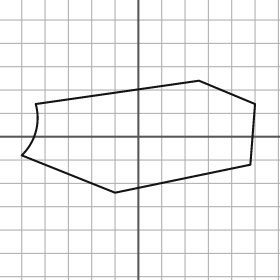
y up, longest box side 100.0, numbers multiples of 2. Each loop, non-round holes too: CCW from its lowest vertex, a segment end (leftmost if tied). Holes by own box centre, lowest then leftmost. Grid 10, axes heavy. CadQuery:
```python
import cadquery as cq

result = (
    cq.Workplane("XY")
    .moveTo(-10.0, -24.0)
    .lineTo(48.0, -12.0)
    .lineTo(50.0, 14.0)
    .lineTo(26.0, 24.0)
    .lineTo(-44.0, 14.0)
    .threePointArc((-44.0, 2.0), (-50.0, -8.0))
    .close()
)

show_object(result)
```